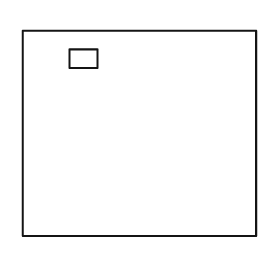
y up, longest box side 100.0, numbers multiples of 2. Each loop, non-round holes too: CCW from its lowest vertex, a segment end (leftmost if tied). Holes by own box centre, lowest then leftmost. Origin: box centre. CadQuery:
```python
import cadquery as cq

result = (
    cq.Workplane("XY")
    .moveTo(-50.0, -44.0)
    .lineTo(50.0, -44.0)
    .lineTo(50.0, 44.0)
    .lineTo(-50.0, 44.0)
    .close()
    .moveTo(-30.0, 28.0)
    .lineTo(-18.0, 28.0)
    .lineTo(-18.0, 36.0)
    .lineTo(-30.0, 36.0)
    .close()
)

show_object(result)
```